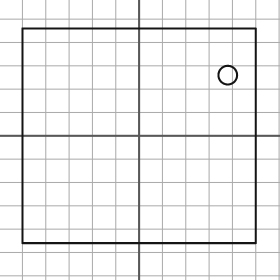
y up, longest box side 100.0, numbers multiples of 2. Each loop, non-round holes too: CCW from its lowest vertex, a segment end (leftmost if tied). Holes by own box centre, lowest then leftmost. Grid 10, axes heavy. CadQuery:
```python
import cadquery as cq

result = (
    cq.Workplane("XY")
    .moveTo(-50.0, -46.0)
    .lineTo(50.0, -46.0)
    .lineTo(50.0, 46.0)
    .lineTo(-50.0, 46.0)
    .close()
    .moveTo(38.0, 26.0)
    .circle(4.0)
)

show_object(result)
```